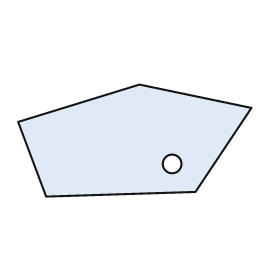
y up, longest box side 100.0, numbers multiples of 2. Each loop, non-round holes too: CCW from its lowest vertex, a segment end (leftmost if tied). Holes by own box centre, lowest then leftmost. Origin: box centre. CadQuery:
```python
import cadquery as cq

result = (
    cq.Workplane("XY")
    .moveTo(-38.0, -24.0)
    .lineTo(26.0, -22.0)
    .lineTo(50.0, 14.0)
    .lineTo(2.0, 24.0)
    .lineTo(-50.0, 8.0)
    .close()
    .moveTo(16.0, -10.0)
    .circle(4.0)
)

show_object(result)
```